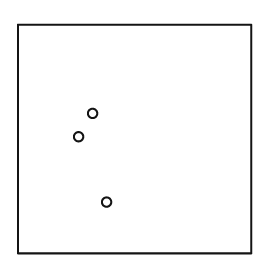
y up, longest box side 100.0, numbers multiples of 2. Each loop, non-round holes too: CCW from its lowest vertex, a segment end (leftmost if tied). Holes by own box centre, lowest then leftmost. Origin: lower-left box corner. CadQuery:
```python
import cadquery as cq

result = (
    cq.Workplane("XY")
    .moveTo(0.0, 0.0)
    .lineTo(100.0, 0.0)
    .lineTo(100.0, 98.0)
    .lineTo(0.0, 98.0)
    .close()
    .moveTo(38.0, 22.0)
    .circle(2.0)
    .moveTo(26.0, 50.0)
    .circle(2.0)
    .moveTo(32.0, 60.0)
    .circle(2.0)
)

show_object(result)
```